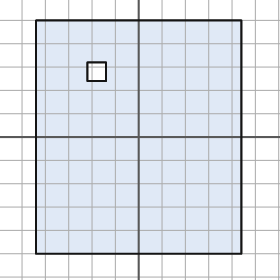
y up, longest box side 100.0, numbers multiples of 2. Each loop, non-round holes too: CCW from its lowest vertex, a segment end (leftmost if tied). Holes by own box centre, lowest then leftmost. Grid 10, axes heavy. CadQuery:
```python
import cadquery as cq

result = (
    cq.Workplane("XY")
    .moveTo(-44.0, -50.0)
    .lineTo(44.0, -50.0)
    .lineTo(44.0, 50.0)
    .lineTo(-44.0, 50.0)
    .close()
    .moveTo(-22.0, 24.0)
    .lineTo(-14.0, 24.0)
    .lineTo(-14.0, 32.0)
    .lineTo(-22.0, 32.0)
    .close()
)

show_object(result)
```